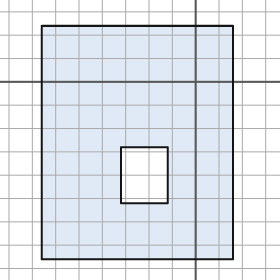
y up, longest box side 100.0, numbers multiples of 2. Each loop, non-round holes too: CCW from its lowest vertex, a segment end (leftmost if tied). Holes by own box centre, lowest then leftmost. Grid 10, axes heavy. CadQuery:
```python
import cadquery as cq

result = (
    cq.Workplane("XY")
    .moveTo(-66.0, -76.0)
    .lineTo(16.0, -76.0)
    .lineTo(16.0, 24.0)
    .lineTo(-66.0, 24.0)
    .close()
    .moveTo(-32.0, -52.0)
    .lineTo(-12.0, -52.0)
    .lineTo(-12.0, -28.0)
    .lineTo(-32.0, -28.0)
    .close()
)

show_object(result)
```